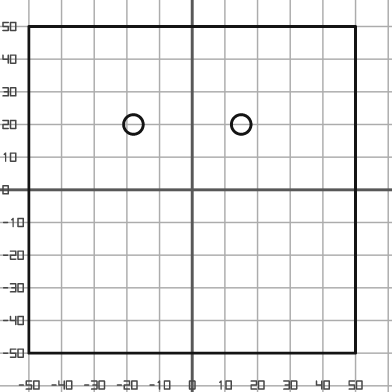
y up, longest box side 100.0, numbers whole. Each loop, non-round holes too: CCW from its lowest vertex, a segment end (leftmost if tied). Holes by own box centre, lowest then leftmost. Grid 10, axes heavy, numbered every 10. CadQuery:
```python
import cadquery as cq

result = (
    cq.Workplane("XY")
    .moveTo(-50.0, -50.0)
    .lineTo(50.0, -50.0)
    .lineTo(50.0, 50.0)
    .lineTo(-50.0, 50.0)
    .close()
    .moveTo(-18.0, 20.0)
    .circle(3.0)
    .moveTo(15.0, 20.0)
    .circle(3.0)
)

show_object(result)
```